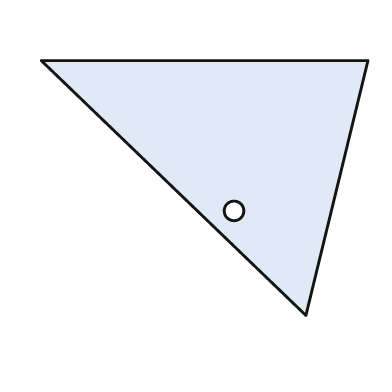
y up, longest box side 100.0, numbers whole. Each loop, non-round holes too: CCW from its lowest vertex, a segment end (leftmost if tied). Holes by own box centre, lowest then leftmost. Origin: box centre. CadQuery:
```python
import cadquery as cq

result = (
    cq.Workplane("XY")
    .moveTo(31.0, -39.0)
    .lineTo(50.0, 39.0)
    .lineTo(-50.0, 39.0)
    .close()
    .moveTo(9.0, -7.0)
    .circle(3.0)
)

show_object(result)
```